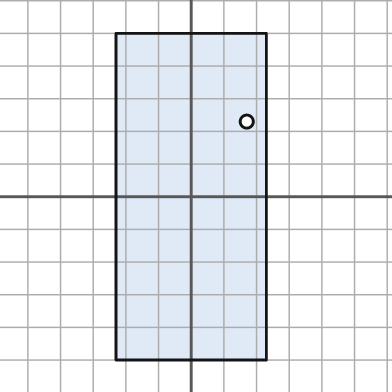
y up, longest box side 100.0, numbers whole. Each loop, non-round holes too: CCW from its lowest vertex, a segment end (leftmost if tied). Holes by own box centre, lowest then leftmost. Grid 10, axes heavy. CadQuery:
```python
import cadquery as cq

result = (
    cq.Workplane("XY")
    .moveTo(-23.0, -50.0)
    .lineTo(23.0, -50.0)
    .lineTo(23.0, 50.0)
    .lineTo(-23.0, 50.0)
    .close()
    .moveTo(17.0, 23.0)
    .circle(2.0)
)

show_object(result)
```